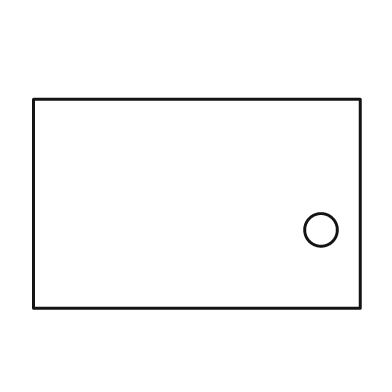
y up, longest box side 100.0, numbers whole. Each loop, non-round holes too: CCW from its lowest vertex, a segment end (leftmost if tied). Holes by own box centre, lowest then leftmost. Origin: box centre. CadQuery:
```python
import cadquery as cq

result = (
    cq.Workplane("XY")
    .moveTo(-50.0, -32.0)
    .lineTo(50.0, -32.0)
    .lineTo(50.0, 32.0)
    .lineTo(-50.0, 32.0)
    .close()
    .moveTo(38.0, -8.0)
    .circle(5.0)
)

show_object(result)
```